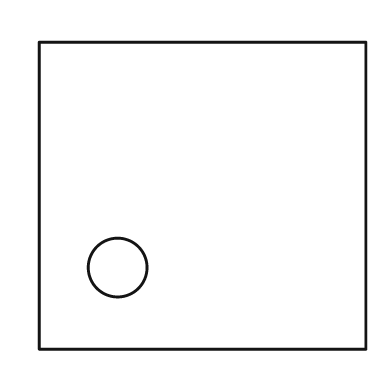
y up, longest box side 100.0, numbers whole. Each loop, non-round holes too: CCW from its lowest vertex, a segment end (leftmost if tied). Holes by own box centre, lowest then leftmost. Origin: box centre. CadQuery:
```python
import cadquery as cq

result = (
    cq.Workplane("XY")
    .moveTo(-50.0, -47.0)
    .lineTo(50.0, -47.0)
    .lineTo(50.0, 47.0)
    .lineTo(-50.0, 47.0)
    .close()
    .moveTo(-26.0, -22.0)
    .circle(9.0)
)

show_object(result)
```